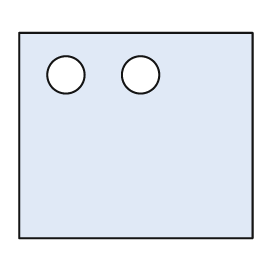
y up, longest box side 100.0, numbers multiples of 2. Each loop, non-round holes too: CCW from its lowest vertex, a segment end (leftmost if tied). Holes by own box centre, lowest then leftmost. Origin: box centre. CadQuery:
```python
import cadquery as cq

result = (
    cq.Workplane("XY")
    .moveTo(-50.0, -44.0)
    .lineTo(50.0, -44.0)
    .lineTo(50.0, 44.0)
    .lineTo(-50.0, 44.0)
    .close()
    .moveTo(-30.0, 26.0)
    .circle(8.0)
    .moveTo(2.0, 26.0)
    .circle(8.0)
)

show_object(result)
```